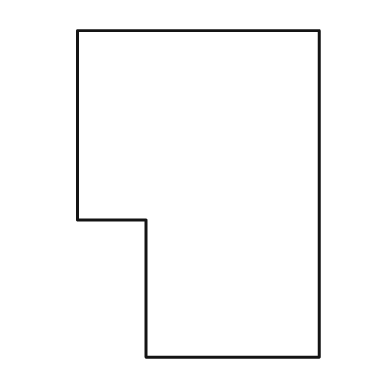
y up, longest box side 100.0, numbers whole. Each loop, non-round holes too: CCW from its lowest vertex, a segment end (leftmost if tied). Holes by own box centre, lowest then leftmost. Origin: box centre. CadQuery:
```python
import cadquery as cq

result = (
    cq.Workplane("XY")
    .moveTo(-16.0, -50.0)
    .lineTo(37.0, -50.0)
    .lineTo(37.0, 50.0)
    .lineTo(-37.0, 50.0)
    .lineTo(-37.0, -8.0)
    .lineTo(-16.0, -8.0)
    .close()
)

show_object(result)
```